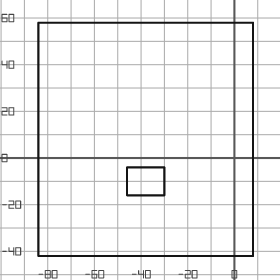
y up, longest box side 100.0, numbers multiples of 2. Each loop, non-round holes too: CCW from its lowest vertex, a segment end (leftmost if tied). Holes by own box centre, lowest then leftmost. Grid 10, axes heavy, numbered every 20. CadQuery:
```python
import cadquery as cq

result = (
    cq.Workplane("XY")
    .moveTo(-84.0, -42.0)
    .lineTo(8.0, -42.0)
    .lineTo(8.0, 58.0)
    .lineTo(-84.0, 58.0)
    .close()
    .moveTo(-46.0, -16.0)
    .lineTo(-30.0, -16.0)
    .lineTo(-30.0, -4.0)
    .lineTo(-46.0, -4.0)
    .close()
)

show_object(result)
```